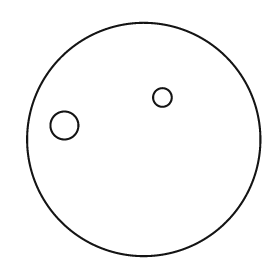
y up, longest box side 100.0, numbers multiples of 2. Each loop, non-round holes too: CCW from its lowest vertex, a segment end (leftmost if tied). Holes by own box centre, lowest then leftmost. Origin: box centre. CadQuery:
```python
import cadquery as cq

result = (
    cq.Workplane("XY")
    .moveTo(0.0, 0.0)
    .circle(50.0)
    .moveTo(-34.0, 6.0)
    .circle(6.0)
    .moveTo(8.0, 18.0)
    .circle(4.0)
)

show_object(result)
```